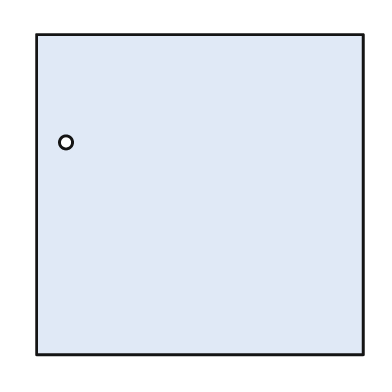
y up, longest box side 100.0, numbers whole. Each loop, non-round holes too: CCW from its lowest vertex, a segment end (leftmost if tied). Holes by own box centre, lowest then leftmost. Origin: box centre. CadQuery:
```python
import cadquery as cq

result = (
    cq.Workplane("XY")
    .moveTo(-50.0, -49.0)
    .lineTo(50.0, -49.0)
    .lineTo(50.0, 49.0)
    .lineTo(-50.0, 49.0)
    .close()
    .moveTo(-41.0, 16.0)
    .circle(2.0)
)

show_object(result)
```